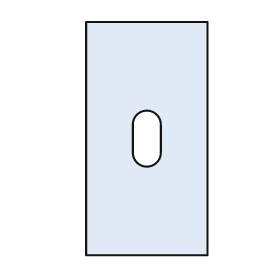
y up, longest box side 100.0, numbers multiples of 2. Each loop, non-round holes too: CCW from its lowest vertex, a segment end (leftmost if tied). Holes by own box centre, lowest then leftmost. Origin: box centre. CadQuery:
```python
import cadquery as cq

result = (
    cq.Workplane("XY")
    .moveTo(-26.0, -50.0)
    .lineTo(26.0, -50.0)
    .lineTo(26.0, 50.0)
    .lineTo(-26.0, 50.0)
    .close()
    .moveTo(-6.0, -6.0)
    .threePointArc((0.0, -12.0), (6.0, -6.0))
    .lineTo(6.0, 6.0)
    .threePointArc((0.0, 12.0), (-6.0, 6.0))
    .close()
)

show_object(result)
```